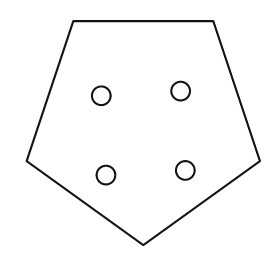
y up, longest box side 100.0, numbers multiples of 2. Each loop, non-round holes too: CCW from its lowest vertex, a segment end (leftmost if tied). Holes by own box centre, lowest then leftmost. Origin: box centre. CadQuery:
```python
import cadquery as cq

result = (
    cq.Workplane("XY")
    .moveTo(0.0, -48.0)
    .lineTo(50.0, -12.0)
    .lineTo(30.0, 48.0)
    .lineTo(-30.0, 48.0)
    .lineTo(-50.0, -12.0)
    .close()
    .moveTo(-16.0, -18.0)
    .circle(4.0)
    .moveTo(18.0, -16.0)
    .circle(4.0)
    .moveTo(-18.0, 16.0)
    .circle(4.0)
    .moveTo(16.0, 18.0)
    .circle(4.0)
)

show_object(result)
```